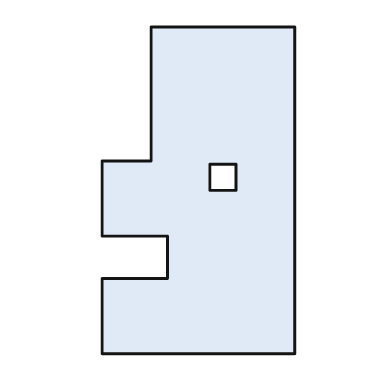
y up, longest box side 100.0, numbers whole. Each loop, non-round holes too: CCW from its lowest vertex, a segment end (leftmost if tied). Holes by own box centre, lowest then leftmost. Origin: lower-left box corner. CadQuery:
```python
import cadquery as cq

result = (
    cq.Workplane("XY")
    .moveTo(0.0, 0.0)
    .lineTo(59.0, 0.0)
    .lineTo(59.0, 100.0)
    .lineTo(15.0, 100.0)
    .lineTo(15.0, 59.0)
    .lineTo(0.0, 59.0)
    .lineTo(0.0, 36.0)
    .lineTo(20.0, 36.0)
    .lineTo(20.0, 23.0)
    .lineTo(0.0, 23.0)
    .close()
    .moveTo(33.0, 50.0)
    .lineTo(41.0, 50.0)
    .lineTo(41.0, 58.0)
    .lineTo(33.0, 58.0)
    .close()
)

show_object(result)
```